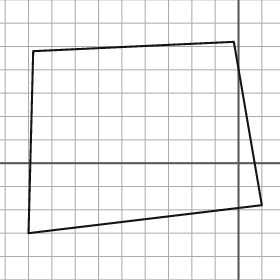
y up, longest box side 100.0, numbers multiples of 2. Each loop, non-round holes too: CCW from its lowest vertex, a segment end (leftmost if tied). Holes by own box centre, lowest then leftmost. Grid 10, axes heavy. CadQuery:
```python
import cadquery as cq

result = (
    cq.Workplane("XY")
    .moveTo(-90.0, -30.0)
    .lineTo(10.0, -18.0)
    .lineTo(-2.0, 52.0)
    .lineTo(-88.0, 48.0)
    .close()
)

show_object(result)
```